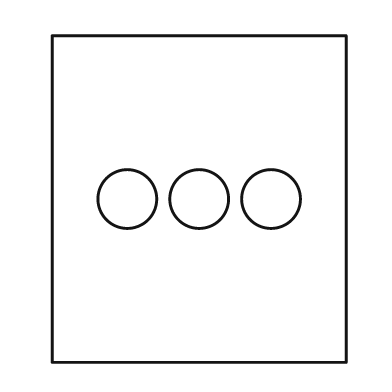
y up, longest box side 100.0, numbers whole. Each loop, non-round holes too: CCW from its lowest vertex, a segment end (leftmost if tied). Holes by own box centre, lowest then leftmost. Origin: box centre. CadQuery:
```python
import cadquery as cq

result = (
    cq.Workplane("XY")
    .moveTo(-45.0, -50.0)
    .lineTo(45.0, -50.0)
    .lineTo(45.0, 50.0)
    .lineTo(-45.0, 50.0)
    .close()
    .moveTo(-22.0, 0.0)
    .circle(9.0)
    .moveTo(0.0, 0.0)
    .circle(9.0)
    .moveTo(22.0, 0.0)
    .circle(9.0)
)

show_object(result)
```